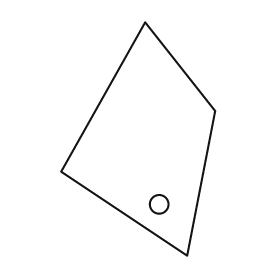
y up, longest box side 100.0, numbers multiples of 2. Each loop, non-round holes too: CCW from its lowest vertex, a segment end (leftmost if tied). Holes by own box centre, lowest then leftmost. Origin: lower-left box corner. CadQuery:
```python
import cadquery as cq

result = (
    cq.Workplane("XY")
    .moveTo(54.0, 0.0)
    .lineTo(66.0, 62.0)
    .lineTo(36.0, 100.0)
    .lineTo(0.0, 36.0)
    .close()
    .moveTo(42.0, 22.0)
    .circle(4.0)
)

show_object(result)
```